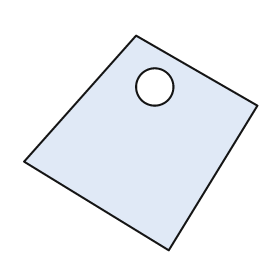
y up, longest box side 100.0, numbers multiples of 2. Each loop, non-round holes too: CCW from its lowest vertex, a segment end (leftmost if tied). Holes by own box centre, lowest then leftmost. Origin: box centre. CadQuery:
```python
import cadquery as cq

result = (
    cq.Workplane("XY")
    .moveTo(12.0, -46.0)
    .lineTo(50.0, 16.0)
    .lineTo(-2.0, 46.0)
    .lineTo(-50.0, -8.0)
    .close()
    .moveTo(6.0, 24.0)
    .circle(8.0)
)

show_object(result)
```